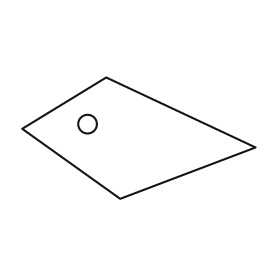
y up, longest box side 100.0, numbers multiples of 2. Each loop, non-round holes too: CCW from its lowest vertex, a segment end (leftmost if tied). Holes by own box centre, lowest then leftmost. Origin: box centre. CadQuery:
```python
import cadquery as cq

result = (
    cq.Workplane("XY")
    .moveTo(-8.0, -26.0)
    .lineTo(50.0, -4.0)
    .lineTo(-14.0, 26.0)
    .lineTo(-50.0, 4.0)
    .close()
    .moveTo(-22.0, 6.0)
    .circle(4.0)
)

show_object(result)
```